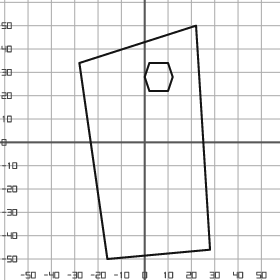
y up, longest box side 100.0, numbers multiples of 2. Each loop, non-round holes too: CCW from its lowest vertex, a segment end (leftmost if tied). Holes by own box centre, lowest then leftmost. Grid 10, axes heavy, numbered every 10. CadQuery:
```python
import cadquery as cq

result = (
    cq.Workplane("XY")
    .moveTo(-16.0, -50.0)
    .lineTo(28.0, -46.0)
    .lineTo(22.0, 50.0)
    .lineTo(-28.0, 34.0)
    .close()
    .moveTo(2.0, 22.0)
    .lineTo(10.0, 22.0)
    .lineTo(12.0, 28.0)
    .lineTo(10.0, 34.0)
    .lineTo(2.0, 34.0)
    .lineTo(0.0, 28.0)
    .close()
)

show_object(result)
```